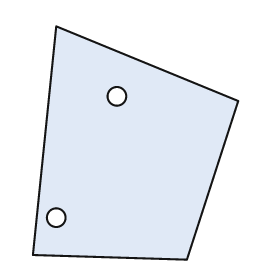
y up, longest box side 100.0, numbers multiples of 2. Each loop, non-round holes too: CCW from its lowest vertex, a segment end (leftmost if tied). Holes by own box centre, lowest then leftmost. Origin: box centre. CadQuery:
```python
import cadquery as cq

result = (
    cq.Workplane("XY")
    .moveTo(22.0, -50.0)
    .lineTo(44.0, 18.0)
    .lineTo(-34.0, 50.0)
    .lineTo(-44.0, -48.0)
    .close()
    .moveTo(-34.0, -32.0)
    .circle(4.0)
    .moveTo(-8.0, 20.0)
    .circle(4.0)
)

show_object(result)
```